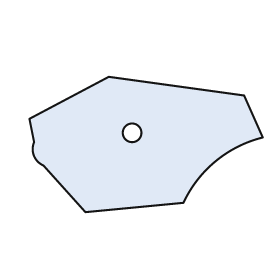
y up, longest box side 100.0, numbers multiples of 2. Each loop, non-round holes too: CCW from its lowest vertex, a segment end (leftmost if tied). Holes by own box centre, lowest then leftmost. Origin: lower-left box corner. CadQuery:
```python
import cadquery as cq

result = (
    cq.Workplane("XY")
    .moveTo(24.0, 0.0)
    .lineTo(66.0, 4.0)
    .threePointArc((80.0, 22.0), (100.0, 32.0))
    .lineTo(92.0, 50.0)
    .lineTo(34.0, 58.0)
    .lineTo(0.0, 40.0)
    .lineTo(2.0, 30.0)
    .threePointArc((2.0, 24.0), (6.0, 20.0))
    .close()
    .moveTo(44.0, 34.0)
    .circle(4.0)
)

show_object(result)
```